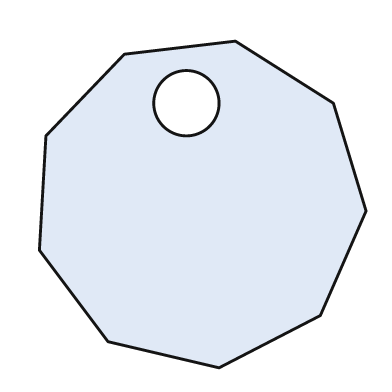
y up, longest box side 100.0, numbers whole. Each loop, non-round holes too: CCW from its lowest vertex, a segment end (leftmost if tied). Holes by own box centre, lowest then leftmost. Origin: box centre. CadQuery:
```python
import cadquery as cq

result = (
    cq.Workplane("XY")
    .moveTo(5.0, -50.0)
    .lineTo(36.0, -34.0)
    .lineTo(50.0, -2.0)
    .lineTo(40.0, 31.0)
    .lineTo(10.0, 50.0)
    .lineTo(-24.0, 46.0)
    .lineTo(-48.0, 21.0)
    .lineTo(-50.0, -14.0)
    .lineTo(-29.0, -42.0)
    .close()
    .moveTo(-5.0, 31.0)
    .circle(10.0)
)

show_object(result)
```